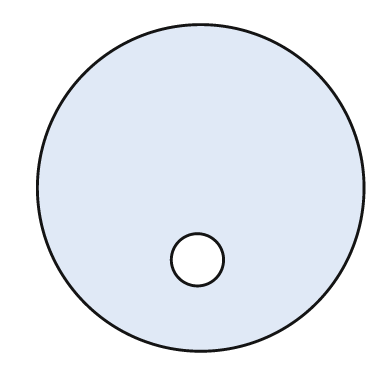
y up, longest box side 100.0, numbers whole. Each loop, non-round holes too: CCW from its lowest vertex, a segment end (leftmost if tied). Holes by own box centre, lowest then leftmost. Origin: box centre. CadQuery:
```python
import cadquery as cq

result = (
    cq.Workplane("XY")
    .moveTo(0.0, 0.0)
    .circle(50.0)
    .moveTo(-1.0, -22.0)
    .circle(8.0)
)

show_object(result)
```